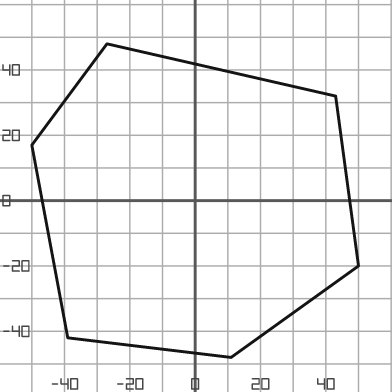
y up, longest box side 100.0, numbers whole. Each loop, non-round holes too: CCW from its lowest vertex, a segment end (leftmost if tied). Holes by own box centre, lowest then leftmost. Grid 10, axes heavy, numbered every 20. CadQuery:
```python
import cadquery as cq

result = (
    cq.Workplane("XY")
    .moveTo(11.0, -48.0)
    .lineTo(50.0, -20.0)
    .lineTo(43.0, 32.0)
    .lineTo(-27.0, 48.0)
    .lineTo(-50.0, 17.0)
    .lineTo(-39.0, -42.0)
    .close()
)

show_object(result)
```